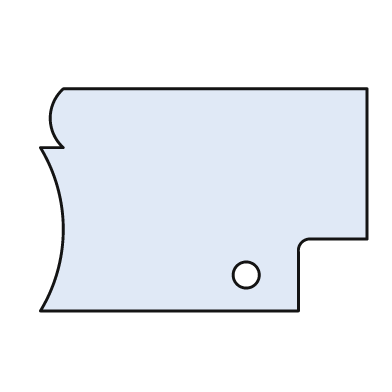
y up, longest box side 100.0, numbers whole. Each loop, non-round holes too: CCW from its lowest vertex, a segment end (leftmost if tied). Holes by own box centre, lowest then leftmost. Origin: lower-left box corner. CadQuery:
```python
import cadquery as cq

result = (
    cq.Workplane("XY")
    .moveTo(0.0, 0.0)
    .lineTo(79.0, 0.0)
    .lineTo(79.0, 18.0)
    .threePointArc((80.0, 21.0), (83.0, 22.0))
    .lineTo(100.0, 22.0)
    .lineTo(100.0, 68.0)
    .lineTo(7.0, 68.0)
    .threePointArc((3.0, 59.0), (7.0, 50.0))
    .lineTo(0.0, 50.0)
    .threePointArc((7.0, 25.0), (0.0, 0.0))
    .close()
    .moveTo(63.0, 11.0)
    .circle(4.0)
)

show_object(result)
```